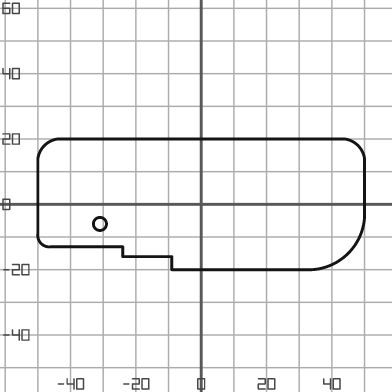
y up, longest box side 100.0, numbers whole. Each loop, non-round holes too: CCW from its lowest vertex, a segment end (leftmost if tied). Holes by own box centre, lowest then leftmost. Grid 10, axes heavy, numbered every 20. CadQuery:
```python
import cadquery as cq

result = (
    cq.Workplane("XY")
    .moveTo(-9.0, -20.0)
    .lineTo(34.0, -20.0)
    .threePointArc((45.0, -15.0), (50.0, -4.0))
    .lineTo(50.0, 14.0)
    .threePointArc((48.0, 18.0), (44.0, 20.0))
    .lineTo(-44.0, 20.0)
    .threePointArc((-48.0, 18.0), (-50.0, 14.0))
    .lineTo(-50.0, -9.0)
    .threePointArc((-49.0, -12.0), (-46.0, -13.0))
    .lineTo(-24.0, -13.0)
    .lineTo(-24.0, -16.0)
    .lineTo(-9.0, -16.0)
    .close()
    .moveTo(-31.0, -6.0)
    .circle(2.0)
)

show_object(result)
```